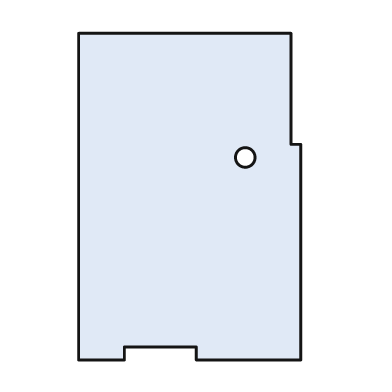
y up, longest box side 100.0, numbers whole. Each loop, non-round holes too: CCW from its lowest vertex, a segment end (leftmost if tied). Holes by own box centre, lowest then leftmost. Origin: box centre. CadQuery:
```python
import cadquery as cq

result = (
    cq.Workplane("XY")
    .moveTo(-34.0, -50.0)
    .lineTo(-20.0, -50.0)
    .lineTo(-20.0, -46.0)
    .lineTo(2.0, -46.0)
    .lineTo(2.0, -50.0)
    .lineTo(34.0, -50.0)
    .lineTo(34.0, 16.0)
    .lineTo(31.0, 16.0)
    .lineTo(31.0, 50.0)
    .lineTo(-34.0, 50.0)
    .close()
    .moveTo(17.0, 12.0)
    .circle(3.0)
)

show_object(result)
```